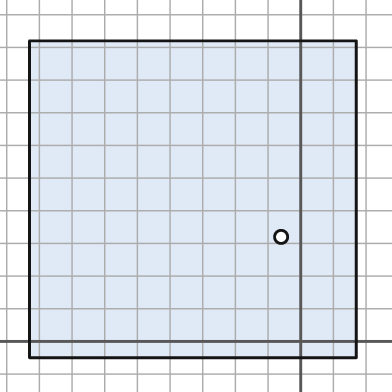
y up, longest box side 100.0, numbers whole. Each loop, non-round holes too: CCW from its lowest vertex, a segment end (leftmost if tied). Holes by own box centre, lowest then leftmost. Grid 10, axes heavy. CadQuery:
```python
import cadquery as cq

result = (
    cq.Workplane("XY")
    .moveTo(-83.0, -5.0)
    .lineTo(17.0, -5.0)
    .lineTo(17.0, 92.0)
    .lineTo(-83.0, 92.0)
    .close()
    .moveTo(-6.0, 32.0)
    .circle(2.0)
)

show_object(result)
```